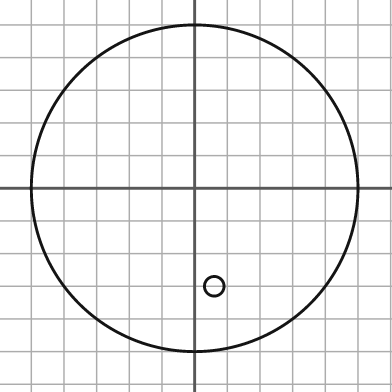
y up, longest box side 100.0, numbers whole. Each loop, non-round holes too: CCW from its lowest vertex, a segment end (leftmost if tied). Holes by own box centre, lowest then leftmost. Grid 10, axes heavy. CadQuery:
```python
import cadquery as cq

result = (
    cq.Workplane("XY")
    .moveTo(0.0, 0.0)
    .circle(50.0)
    .moveTo(6.0, -30.0)
    .circle(3.0)
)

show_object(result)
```